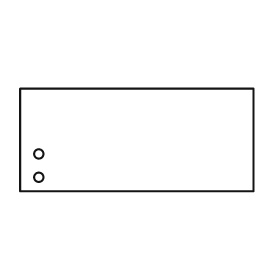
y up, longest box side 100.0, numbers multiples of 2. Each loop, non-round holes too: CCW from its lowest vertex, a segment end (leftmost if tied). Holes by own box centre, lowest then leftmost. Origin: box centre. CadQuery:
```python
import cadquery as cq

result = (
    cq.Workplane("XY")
    .moveTo(-50.0, -22.0)
    .lineTo(50.0, -22.0)
    .lineTo(50.0, 22.0)
    .lineTo(-50.0, 22.0)
    .close()
    .moveTo(-42.0, -16.0)
    .circle(2.0)
    .moveTo(-42.0, -6.0)
    .circle(2.0)
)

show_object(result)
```